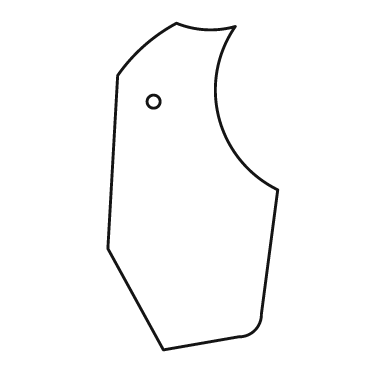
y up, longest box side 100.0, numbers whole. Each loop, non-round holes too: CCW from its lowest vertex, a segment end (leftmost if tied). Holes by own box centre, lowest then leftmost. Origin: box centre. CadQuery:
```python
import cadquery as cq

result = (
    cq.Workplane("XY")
    .moveTo(-9.0, -50.0)
    .lineTo(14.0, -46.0)
    .threePointArc((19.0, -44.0), (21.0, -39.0))
    .lineTo(26.0, -1.0)
    .threePointArc((8.0, 21.0), (13.0, 49.0))
    .threePointArc((4.0, 48.0), (-5.0, 50.0))
    .threePointArc((-15.0, 43.0), (-23.0, 34.0))
    .lineTo(-26.0, -19.0)
    .close()
    .moveTo(-12.0, 26.0)
    .circle(2.0)
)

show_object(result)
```